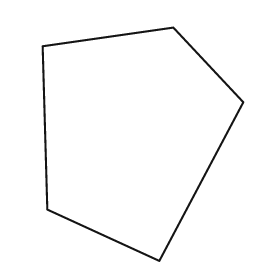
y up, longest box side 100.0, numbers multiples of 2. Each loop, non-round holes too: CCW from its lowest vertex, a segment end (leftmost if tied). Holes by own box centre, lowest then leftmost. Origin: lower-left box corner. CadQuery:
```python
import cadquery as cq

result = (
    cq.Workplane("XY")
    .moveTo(50.0, 0.0)
    .lineTo(86.0, 68.0)
    .lineTo(56.0, 100.0)
    .lineTo(0.0, 92.0)
    .lineTo(2.0, 22.0)
    .close()
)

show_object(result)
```